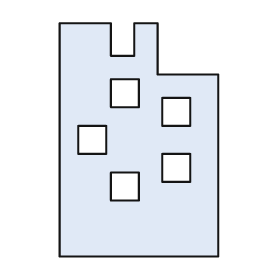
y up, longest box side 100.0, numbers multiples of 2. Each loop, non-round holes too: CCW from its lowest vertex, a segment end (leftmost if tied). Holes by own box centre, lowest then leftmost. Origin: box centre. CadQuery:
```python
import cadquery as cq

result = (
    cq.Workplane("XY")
    .moveTo(-34.0, -50.0)
    .lineTo(34.0, -50.0)
    .lineTo(34.0, 28.0)
    .lineTo(8.0, 28.0)
    .lineTo(8.0, 50.0)
    .lineTo(-2.0, 50.0)
    .lineTo(-2.0, 36.0)
    .lineTo(-12.0, 36.0)
    .lineTo(-12.0, 50.0)
    .lineTo(-34.0, 50.0)
    .close()
    .moveTo(-12.0, -26.0)
    .lineTo(0.0, -26.0)
    .lineTo(0.0, -14.0)
    .lineTo(-12.0, -14.0)
    .close()
    .moveTo(10.0, -18.0)
    .lineTo(22.0, -18.0)
    .lineTo(22.0, -6.0)
    .lineTo(10.0, -6.0)
    .close()
    .moveTo(-26.0, -6.0)
    .lineTo(-14.0, -6.0)
    .lineTo(-14.0, 6.0)
    .lineTo(-26.0, 6.0)
    .close()
    .moveTo(10.0, 6.0)
    .lineTo(22.0, 6.0)
    .lineTo(22.0, 18.0)
    .lineTo(10.0, 18.0)
    .close()
    .moveTo(-12.0, 14.0)
    .lineTo(0.0, 14.0)
    .lineTo(0.0, 26.0)
    .lineTo(-12.0, 26.0)
    .close()
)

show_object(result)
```